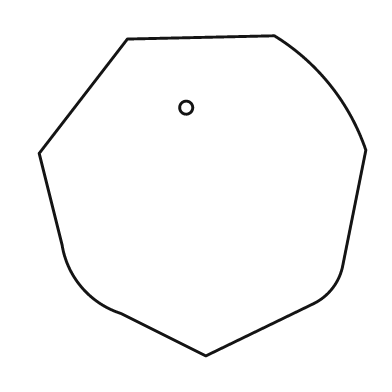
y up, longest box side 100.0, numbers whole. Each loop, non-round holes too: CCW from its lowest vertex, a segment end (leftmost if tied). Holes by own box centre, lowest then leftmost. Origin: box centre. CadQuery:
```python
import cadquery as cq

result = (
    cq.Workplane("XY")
    .moveTo(1.0, -49.0)
    .lineTo(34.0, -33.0)
    .threePointArc((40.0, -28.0), (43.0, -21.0))
    .lineTo(50.0, 14.0)
    .threePointArc((39.0, 34.0), (22.0, 49.0))
    .lineTo(-23.0, 48.0)
    .lineTo(-50.0, 13.0)
    .lineTo(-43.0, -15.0)
    .threePointArc((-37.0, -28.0), (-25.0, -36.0))
    .close()
    .moveTo(-5.0, 27.0)
    .circle(2.0)
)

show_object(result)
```